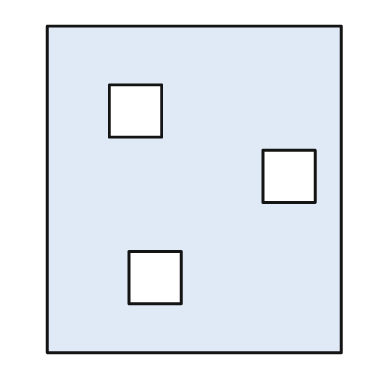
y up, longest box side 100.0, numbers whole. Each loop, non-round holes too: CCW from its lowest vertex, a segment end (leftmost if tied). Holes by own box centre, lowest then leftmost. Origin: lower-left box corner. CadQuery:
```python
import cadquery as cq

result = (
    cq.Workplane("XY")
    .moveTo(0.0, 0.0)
    .lineTo(90.0, 0.0)
    .lineTo(90.0, 100.0)
    .lineTo(0.0, 100.0)
    .close()
    .moveTo(25.0, 15.0)
    .lineTo(41.0, 15.0)
    .lineTo(41.0, 31.0)
    .lineTo(25.0, 31.0)
    .close()
    .moveTo(66.0, 46.0)
    .lineTo(82.0, 46.0)
    .lineTo(82.0, 62.0)
    .lineTo(66.0, 62.0)
    .close()
    .moveTo(19.0, 66.0)
    .lineTo(35.0, 66.0)
    .lineTo(35.0, 82.0)
    .lineTo(19.0, 82.0)
    .close()
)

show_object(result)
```